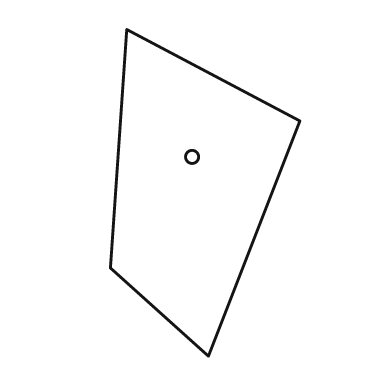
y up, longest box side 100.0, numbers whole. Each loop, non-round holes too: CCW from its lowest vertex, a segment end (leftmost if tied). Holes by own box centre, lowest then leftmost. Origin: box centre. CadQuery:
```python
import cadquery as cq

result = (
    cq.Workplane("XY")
    .moveTo(1.0, -50.0)
    .lineTo(29.0, 22.0)
    .lineTo(-24.0, 50.0)
    .lineTo(-29.0, -23.0)
    .close()
    .moveTo(-4.0, 11.0)
    .circle(2.0)
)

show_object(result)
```